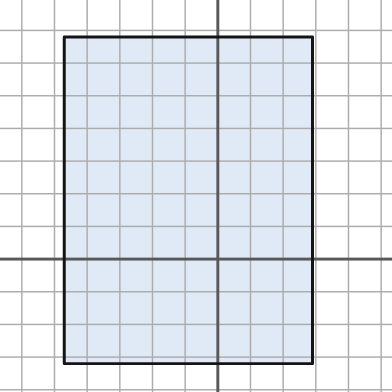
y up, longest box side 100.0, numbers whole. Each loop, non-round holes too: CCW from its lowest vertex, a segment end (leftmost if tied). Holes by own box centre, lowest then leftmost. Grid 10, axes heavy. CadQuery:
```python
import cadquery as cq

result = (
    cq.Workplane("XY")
    .moveTo(-47.0, -32.0)
    .lineTo(29.0, -32.0)
    .lineTo(29.0, 68.0)
    .lineTo(-47.0, 68.0)
    .close()
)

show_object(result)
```